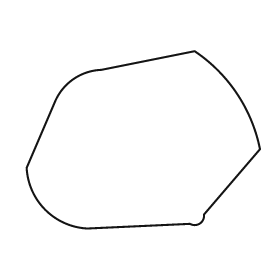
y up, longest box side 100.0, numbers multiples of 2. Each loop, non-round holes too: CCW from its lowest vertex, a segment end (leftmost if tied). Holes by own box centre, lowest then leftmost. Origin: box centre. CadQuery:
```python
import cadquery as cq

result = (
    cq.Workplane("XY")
    .moveTo(-24.0, -38.0)
    .lineTo(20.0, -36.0)
    .threePointArc((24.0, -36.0), (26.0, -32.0))
    .lineTo(50.0, -4.0)
    .threePointArc((40.0, 20.0), (22.0, 38.0))
    .lineTo(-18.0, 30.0)
    .threePointArc((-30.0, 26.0), (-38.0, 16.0))
    .lineTo(-50.0, -12.0)
    .threePointArc((-42.0, -30.0), (-24.0, -38.0))
    .close()
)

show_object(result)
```